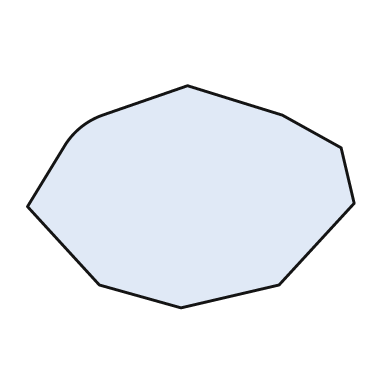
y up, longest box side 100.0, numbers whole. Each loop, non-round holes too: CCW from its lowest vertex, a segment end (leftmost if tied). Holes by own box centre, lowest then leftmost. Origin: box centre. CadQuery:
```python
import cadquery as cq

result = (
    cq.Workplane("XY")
    .moveTo(-3.0, -34.0)
    .lineTo(27.0, -27.0)
    .lineTo(50.0, -2.0)
    .lineTo(46.0, 15.0)
    .lineTo(28.0, 25.0)
    .lineTo(-1.0, 34.0)
    .lineTo(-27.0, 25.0)
    .threePointArc((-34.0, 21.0), (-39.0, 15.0))
    .lineTo(-50.0, -3.0)
    .lineTo(-28.0, -27.0)
    .close()
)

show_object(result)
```